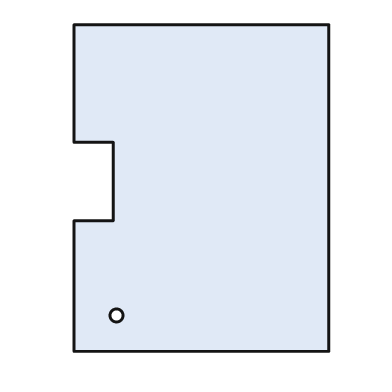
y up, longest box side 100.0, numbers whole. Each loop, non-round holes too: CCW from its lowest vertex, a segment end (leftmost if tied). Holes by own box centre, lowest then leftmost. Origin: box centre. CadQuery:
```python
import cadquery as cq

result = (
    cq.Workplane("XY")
    .moveTo(-39.0, -50.0)
    .lineTo(39.0, -50.0)
    .lineTo(39.0, 50.0)
    .lineTo(-39.0, 50.0)
    .lineTo(-39.0, 14.0)
    .lineTo(-27.0, 14.0)
    .lineTo(-27.0, -10.0)
    .lineTo(-39.0, -10.0)
    .close()
    .moveTo(-26.0, -39.0)
    .circle(2.0)
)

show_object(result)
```